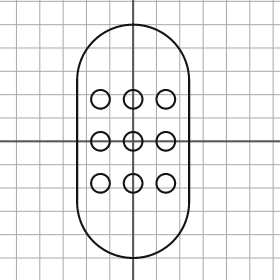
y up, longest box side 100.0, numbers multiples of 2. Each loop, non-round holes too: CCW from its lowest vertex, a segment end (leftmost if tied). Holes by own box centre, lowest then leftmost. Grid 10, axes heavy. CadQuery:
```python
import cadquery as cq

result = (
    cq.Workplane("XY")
    .moveTo(-24.0, -26.0)
    .threePointArc((0.0, -50.0), (24.0, -26.0))
    .lineTo(24.0, 26.0)
    .threePointArc((0.0, 50.0), (-24.0, 26.0))
    .close()
    .moveTo(-14.0, -18.0)
    .circle(4.0)
    .moveTo(0.0, -18.0)
    .circle(4.0)
    .moveTo(14.0, -18.0)
    .circle(4.0)
    .moveTo(-14.0, 0.0)
    .circle(4.0)
    .moveTo(0.0, 0.0)
    .circle(4.0)
    .moveTo(14.0, 0.0)
    .circle(4.0)
    .moveTo(-14.0, 18.0)
    .circle(4.0)
    .moveTo(0.0, 18.0)
    .circle(4.0)
    .moveTo(14.0, 18.0)
    .circle(4.0)
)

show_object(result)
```